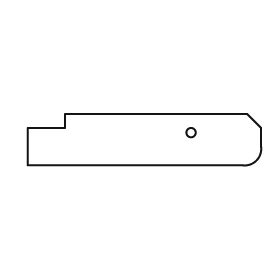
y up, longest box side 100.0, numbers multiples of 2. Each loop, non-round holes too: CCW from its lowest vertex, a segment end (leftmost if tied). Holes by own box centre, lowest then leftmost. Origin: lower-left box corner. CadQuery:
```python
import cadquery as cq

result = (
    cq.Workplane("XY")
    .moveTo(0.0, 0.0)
    .lineTo(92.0, 0.0)
    .threePointArc((98.0, 2.0), (100.0, 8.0))
    .lineTo(100.0, 16.0)
    .lineTo(94.0, 22.0)
    .lineTo(16.0, 22.0)
    .lineTo(16.0, 16.0)
    .lineTo(0.0, 16.0)
    .close()
    .moveTo(70.0, 14.0)
    .circle(2.0)
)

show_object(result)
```